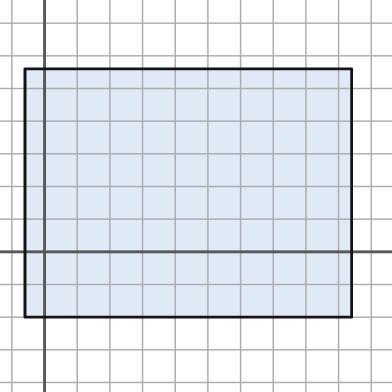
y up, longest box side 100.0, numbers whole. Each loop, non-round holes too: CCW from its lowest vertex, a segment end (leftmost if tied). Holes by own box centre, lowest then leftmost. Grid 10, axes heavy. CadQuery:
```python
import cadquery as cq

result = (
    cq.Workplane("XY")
    .moveTo(-6.0, -20.0)
    .lineTo(94.0, -20.0)
    .lineTo(94.0, 56.0)
    .lineTo(-6.0, 56.0)
    .close()
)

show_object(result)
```